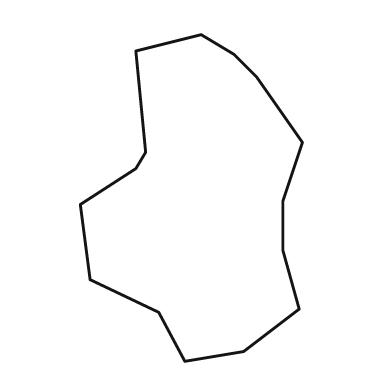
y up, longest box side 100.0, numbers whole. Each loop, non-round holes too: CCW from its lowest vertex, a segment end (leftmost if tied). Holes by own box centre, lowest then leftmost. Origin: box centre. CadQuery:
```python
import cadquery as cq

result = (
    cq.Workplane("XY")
    .moveTo(-2.0, -50.0)
    .lineTo(16.0, -47.0)
    .lineTo(33.0, -34.0)
    .lineTo(28.0, -16.0)
    .lineTo(28.0, -1.0)
    .lineTo(34.0, 17.0)
    .lineTo(20.0, 37.0)
    .lineTo(13.0, 44.0)
    .lineTo(3.0, 50.0)
    .lineTo(-17.0, 45.0)
    .lineTo(-14.0, 14.0)
    .lineTo(-17.0, 9.0)
    .lineTo(-34.0, -2.0)
    .lineTo(-31.0, -25.0)
    .lineTo(-10.0, -35.0)
    .close()
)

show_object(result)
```